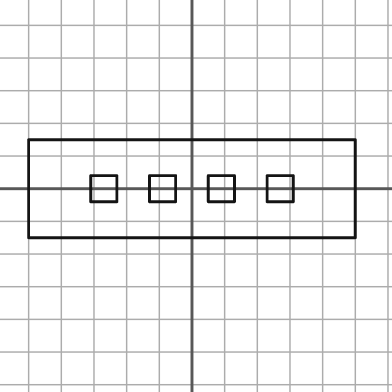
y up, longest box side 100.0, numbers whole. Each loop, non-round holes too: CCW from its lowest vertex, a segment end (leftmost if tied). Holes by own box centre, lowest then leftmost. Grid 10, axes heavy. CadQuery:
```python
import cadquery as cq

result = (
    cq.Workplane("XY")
    .moveTo(-50.0, -15.0)
    .lineTo(50.0, -15.0)
    .lineTo(50.0, 15.0)
    .lineTo(-50.0, 15.0)
    .close()
    .moveTo(-31.0, -4.0)
    .lineTo(-23.0, -4.0)
    .lineTo(-23.0, 4.0)
    .lineTo(-31.0, 4.0)
    .close()
    .moveTo(-13.0, -4.0)
    .lineTo(-5.0, -4.0)
    .lineTo(-5.0, 4.0)
    .lineTo(-13.0, 4.0)
    .close()
    .moveTo(5.0, -4.0)
    .lineTo(13.0, -4.0)
    .lineTo(13.0, 4.0)
    .lineTo(5.0, 4.0)
    .close()
    .moveTo(23.0, -4.0)
    .lineTo(31.0, -4.0)
    .lineTo(31.0, 4.0)
    .lineTo(23.0, 4.0)
    .close()
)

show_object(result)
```